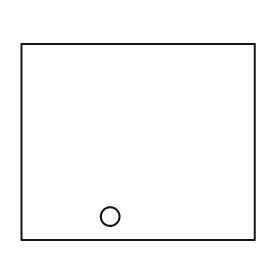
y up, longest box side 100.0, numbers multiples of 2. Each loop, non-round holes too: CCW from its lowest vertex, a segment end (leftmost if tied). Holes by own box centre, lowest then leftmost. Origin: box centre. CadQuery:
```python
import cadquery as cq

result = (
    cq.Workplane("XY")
    .moveTo(-50.0, -42.0)
    .lineTo(50.0, -42.0)
    .lineTo(50.0, 42.0)
    .lineTo(-50.0, 42.0)
    .close()
    .moveTo(-12.0, -32.0)
    .circle(4.0)
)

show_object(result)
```